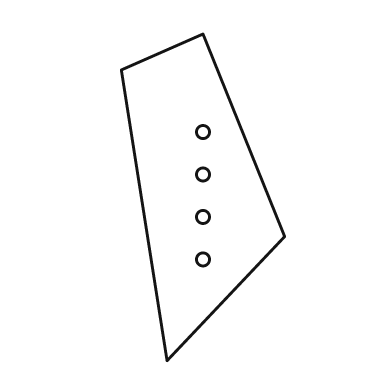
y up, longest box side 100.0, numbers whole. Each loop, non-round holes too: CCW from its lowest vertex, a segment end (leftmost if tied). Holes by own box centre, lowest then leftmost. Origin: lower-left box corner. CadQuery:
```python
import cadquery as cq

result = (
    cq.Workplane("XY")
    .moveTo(14.0, 0.0)
    .lineTo(50.0, 38.0)
    .lineTo(25.0, 100.0)
    .lineTo(0.0, 89.0)
    .close()
    .moveTo(25.0, 31.0)
    .circle(2.0)
    .moveTo(25.0, 44.0)
    .circle(2.0)
    .moveTo(25.0, 57.0)
    .circle(2.0)
    .moveTo(25.0, 70.0)
    .circle(2.0)
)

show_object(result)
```